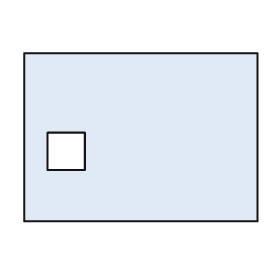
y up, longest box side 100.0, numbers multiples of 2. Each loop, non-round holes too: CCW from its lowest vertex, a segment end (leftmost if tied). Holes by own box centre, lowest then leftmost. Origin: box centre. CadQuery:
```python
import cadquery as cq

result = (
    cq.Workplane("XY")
    .moveTo(-50.0, -36.0)
    .lineTo(50.0, -36.0)
    .lineTo(50.0, 36.0)
    .lineTo(-50.0, 36.0)
    .close()
    .moveTo(-40.0, -14.0)
    .lineTo(-24.0, -14.0)
    .lineTo(-24.0, 2.0)
    .lineTo(-40.0, 2.0)
    .close()
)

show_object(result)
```